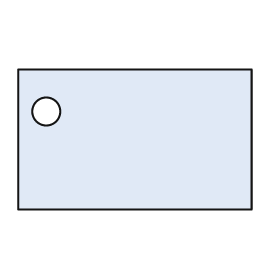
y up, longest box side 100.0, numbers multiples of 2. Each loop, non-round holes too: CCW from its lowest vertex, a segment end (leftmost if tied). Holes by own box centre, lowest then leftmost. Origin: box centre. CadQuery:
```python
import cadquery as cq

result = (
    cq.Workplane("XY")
    .moveTo(-50.0, -30.0)
    .lineTo(50.0, -30.0)
    .lineTo(50.0, 30.0)
    .lineTo(-50.0, 30.0)
    .close()
    .moveTo(-38.0, 12.0)
    .circle(6.0)
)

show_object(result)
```